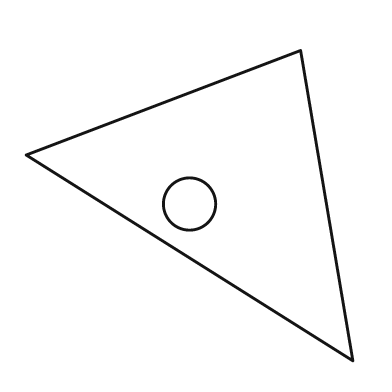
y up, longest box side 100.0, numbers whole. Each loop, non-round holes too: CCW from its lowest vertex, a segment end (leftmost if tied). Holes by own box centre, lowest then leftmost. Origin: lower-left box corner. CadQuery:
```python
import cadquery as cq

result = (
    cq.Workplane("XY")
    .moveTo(100.0, 0.0)
    .lineTo(84.0, 95.0)
    .lineTo(0.0, 63.0)
    .close()
    .moveTo(50.0, 48.0)
    .circle(8.0)
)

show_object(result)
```